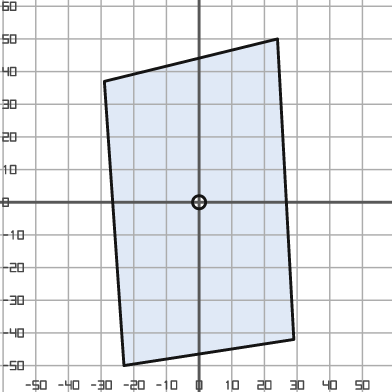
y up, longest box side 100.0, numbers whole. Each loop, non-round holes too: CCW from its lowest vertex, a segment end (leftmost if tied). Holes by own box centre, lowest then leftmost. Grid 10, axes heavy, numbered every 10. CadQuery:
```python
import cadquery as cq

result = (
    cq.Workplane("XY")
    .moveTo(-23.0, -50.0)
    .lineTo(29.0, -42.0)
    .lineTo(24.0, 50.0)
    .lineTo(-29.0, 37.0)
    .close()
    .moveTo(0.0, 0.0)
    .circle(2.0)
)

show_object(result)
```